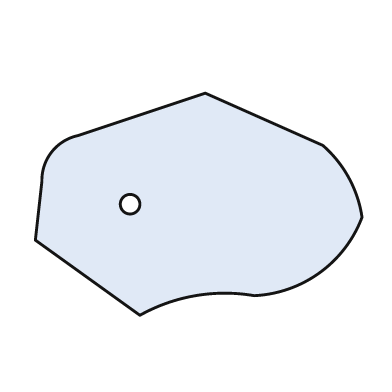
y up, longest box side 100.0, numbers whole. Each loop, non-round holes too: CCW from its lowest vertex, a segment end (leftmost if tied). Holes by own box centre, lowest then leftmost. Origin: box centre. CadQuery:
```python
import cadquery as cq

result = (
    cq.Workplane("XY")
    .moveTo(-18.0, -34.0)
    .threePointArc((-1.0, -28.0), (17.0, -28.0))
    .threePointArc((37.0, -21.0), (50.0, -4.0))
    .threePointArc((46.0, 8.0), (38.0, 18.0))
    .lineTo(2.0, 34.0)
    .lineTo(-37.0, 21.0)
    .threePointArc((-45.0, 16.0), (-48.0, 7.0))
    .lineTo(-50.0, -11.0)
    .close()
    .moveTo(-21.0, 0.0)
    .circle(3.0)
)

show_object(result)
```